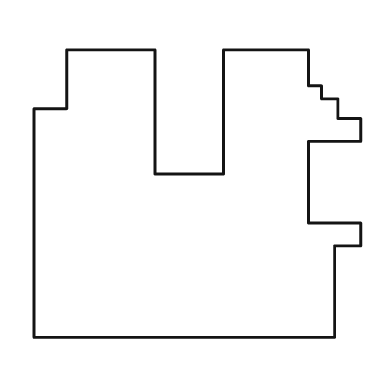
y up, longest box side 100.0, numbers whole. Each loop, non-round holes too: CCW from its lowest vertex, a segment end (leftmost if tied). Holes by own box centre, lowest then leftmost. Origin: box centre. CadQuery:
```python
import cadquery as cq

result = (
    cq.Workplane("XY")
    .moveTo(-50.0, -44.0)
    .lineTo(42.0, -44.0)
    .lineTo(42.0, -16.0)
    .lineTo(50.0, -16.0)
    .lineTo(50.0, -9.0)
    .lineTo(34.0, -9.0)
    .lineTo(34.0, 16.0)
    .lineTo(50.0, 16.0)
    .lineTo(50.0, 23.0)
    .lineTo(43.0, 23.0)
    .lineTo(43.0, 29.0)
    .lineTo(38.0, 29.0)
    .lineTo(38.0, 33.0)
    .lineTo(34.0, 33.0)
    .lineTo(34.0, 44.0)
    .lineTo(8.0, 44.0)
    .lineTo(8.0, 6.0)
    .lineTo(-13.0, 6.0)
    .lineTo(-13.0, 44.0)
    .lineTo(-40.0, 44.0)
    .lineTo(-40.0, 26.0)
    .lineTo(-50.0, 26.0)
    .close()
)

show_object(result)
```